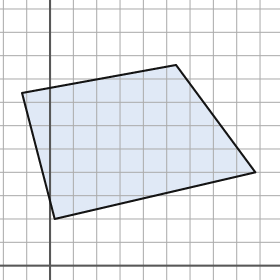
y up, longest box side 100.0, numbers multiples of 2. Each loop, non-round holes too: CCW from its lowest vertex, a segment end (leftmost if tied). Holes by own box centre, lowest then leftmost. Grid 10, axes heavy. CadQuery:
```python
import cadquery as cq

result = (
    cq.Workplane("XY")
    .moveTo(2.0, 20.0)
    .lineTo(88.0, 40.0)
    .lineTo(54.0, 86.0)
    .lineTo(-12.0, 74.0)
    .close()
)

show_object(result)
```